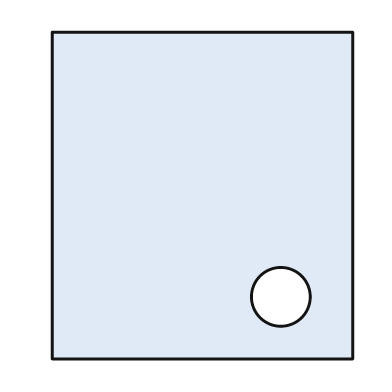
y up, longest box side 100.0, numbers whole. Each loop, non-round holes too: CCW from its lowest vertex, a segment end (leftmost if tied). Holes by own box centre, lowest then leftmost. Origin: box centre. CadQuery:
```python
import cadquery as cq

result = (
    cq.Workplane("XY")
    .moveTo(-46.0, -50.0)
    .lineTo(46.0, -50.0)
    .lineTo(46.0, 50.0)
    .lineTo(-46.0, 50.0)
    .close()
    .moveTo(24.0, -31.0)
    .circle(9.0)
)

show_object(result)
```